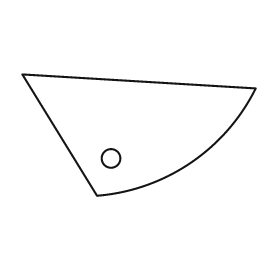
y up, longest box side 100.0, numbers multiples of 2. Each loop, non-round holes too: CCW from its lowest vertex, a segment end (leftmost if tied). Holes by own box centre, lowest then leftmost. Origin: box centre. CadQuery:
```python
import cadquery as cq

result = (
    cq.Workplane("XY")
    .moveTo(-18.0, -26.0)
    .threePointArc((22.0, -12.0), (50.0, 20.0))
    .lineTo(-50.0, 26.0)
    .close()
    .moveTo(-12.0, -10.0)
    .circle(4.0)
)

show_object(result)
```